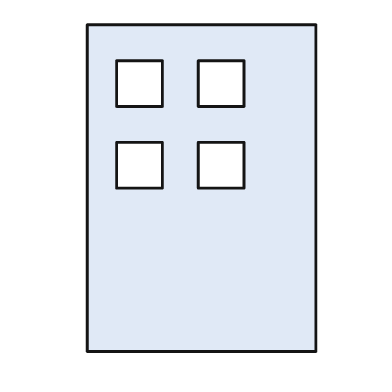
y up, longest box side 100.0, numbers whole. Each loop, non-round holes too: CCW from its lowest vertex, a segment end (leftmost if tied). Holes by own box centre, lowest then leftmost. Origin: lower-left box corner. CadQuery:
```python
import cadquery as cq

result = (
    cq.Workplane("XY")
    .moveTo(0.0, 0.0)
    .lineTo(70.0, 0.0)
    .lineTo(70.0, 100.0)
    .lineTo(0.0, 100.0)
    .close()
    .moveTo(9.0, 50.0)
    .lineTo(23.0, 50.0)
    .lineTo(23.0, 64.0)
    .lineTo(9.0, 64.0)
    .close()
    .moveTo(34.0, 50.0)
    .lineTo(48.0, 50.0)
    .lineTo(48.0, 64.0)
    .lineTo(34.0, 64.0)
    .close()
    .moveTo(9.0, 75.0)
    .lineTo(23.0, 75.0)
    .lineTo(23.0, 89.0)
    .lineTo(9.0, 89.0)
    .close()
    .moveTo(34.0, 75.0)
    .lineTo(48.0, 75.0)
    .lineTo(48.0, 89.0)
    .lineTo(34.0, 89.0)
    .close()
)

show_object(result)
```